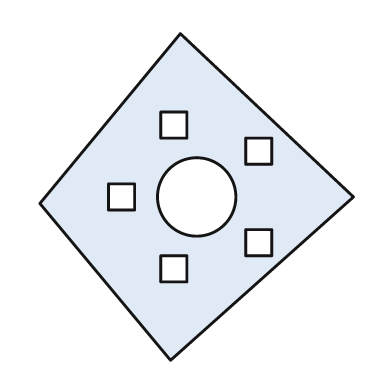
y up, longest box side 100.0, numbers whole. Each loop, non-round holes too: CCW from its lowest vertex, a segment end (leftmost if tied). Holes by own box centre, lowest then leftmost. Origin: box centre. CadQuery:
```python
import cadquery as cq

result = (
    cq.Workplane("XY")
    .moveTo(-8.0, -50.0)
    .lineTo(48.0, 0.0)
    .lineTo(-5.0, 50.0)
    .lineTo(-48.0, -2.0)
    .close()
    .moveTo(-11.0, -26.0)
    .lineTo(-3.0, -26.0)
    .lineTo(-3.0, -18.0)
    .lineTo(-11.0, -18.0)
    .close()
    .moveTo(15.0, -18.0)
    .lineTo(23.0, -18.0)
    .lineTo(23.0, -10.0)
    .lineTo(15.0, -10.0)
    .close()
    .moveTo(-27.0, -4.0)
    .lineTo(-19.0, -4.0)
    .lineTo(-19.0, 4.0)
    .lineTo(-27.0, 4.0)
    .close()
    .moveTo(0.0, 0.0)
    .circle(12.0)
    .moveTo(15.0, 10.0)
    .lineTo(23.0, 10.0)
    .lineTo(23.0, 18.0)
    .lineTo(15.0, 18.0)
    .close()
    .moveTo(-11.0, 18.0)
    .lineTo(-3.0, 18.0)
    .lineTo(-3.0, 26.0)
    .lineTo(-11.0, 26.0)
    .close()
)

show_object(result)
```